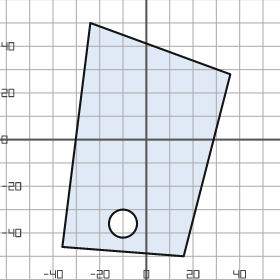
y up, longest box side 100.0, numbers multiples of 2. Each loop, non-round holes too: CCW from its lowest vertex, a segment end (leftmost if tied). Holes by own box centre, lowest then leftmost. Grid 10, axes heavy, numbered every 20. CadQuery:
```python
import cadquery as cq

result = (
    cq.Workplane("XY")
    .moveTo(16.0, -50.0)
    .lineTo(36.0, 28.0)
    .lineTo(-24.0, 50.0)
    .lineTo(-36.0, -46.0)
    .close()
    .moveTo(-10.0, -36.0)
    .circle(6.0)
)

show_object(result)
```